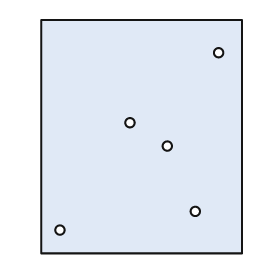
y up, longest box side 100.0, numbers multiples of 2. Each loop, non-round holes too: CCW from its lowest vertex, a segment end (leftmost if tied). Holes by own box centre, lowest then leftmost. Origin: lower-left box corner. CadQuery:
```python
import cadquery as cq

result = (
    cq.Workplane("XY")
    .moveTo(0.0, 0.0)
    .lineTo(86.0, 0.0)
    .lineTo(86.0, 100.0)
    .lineTo(0.0, 100.0)
    .close()
    .moveTo(8.0, 10.0)
    .circle(2.0)
    .moveTo(66.0, 18.0)
    .circle(2.0)
    .moveTo(54.0, 46.0)
    .circle(2.0)
    .moveTo(38.0, 56.0)
    .circle(2.0)
    .moveTo(76.0, 86.0)
    .circle(2.0)
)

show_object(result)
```